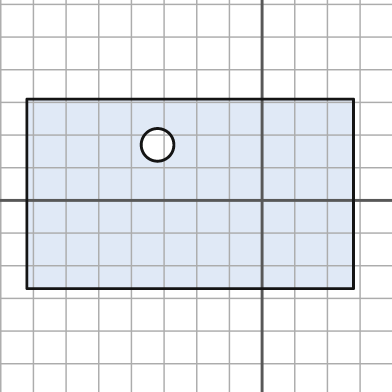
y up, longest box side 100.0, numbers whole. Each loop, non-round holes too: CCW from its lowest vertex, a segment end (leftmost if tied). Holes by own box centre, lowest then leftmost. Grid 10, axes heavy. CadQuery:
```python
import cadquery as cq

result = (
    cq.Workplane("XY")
    .moveTo(-72.0, -27.0)
    .lineTo(28.0, -27.0)
    .lineTo(28.0, 31.0)
    .lineTo(-72.0, 31.0)
    .close()
    .moveTo(-32.0, 17.0)
    .circle(5.0)
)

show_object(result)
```